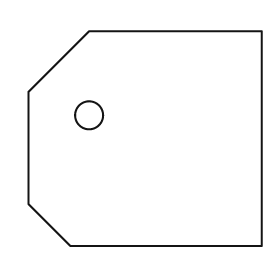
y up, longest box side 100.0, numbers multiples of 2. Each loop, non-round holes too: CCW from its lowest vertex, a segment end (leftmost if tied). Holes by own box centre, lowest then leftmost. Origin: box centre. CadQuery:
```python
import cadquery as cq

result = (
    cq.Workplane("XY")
    .moveTo(-32.0, -46.0)
    .lineTo(50.0, -46.0)
    .lineTo(50.0, 46.0)
    .lineTo(-24.0, 46.0)
    .lineTo(-50.0, 20.0)
    .lineTo(-50.0, -28.0)
    .close()
    .moveTo(-24.0, 10.0)
    .circle(6.0)
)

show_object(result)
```